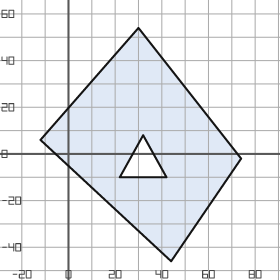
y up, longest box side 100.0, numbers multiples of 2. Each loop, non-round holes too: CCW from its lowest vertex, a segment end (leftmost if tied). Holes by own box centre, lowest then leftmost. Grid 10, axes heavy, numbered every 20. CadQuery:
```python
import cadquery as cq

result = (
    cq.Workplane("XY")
    .moveTo(44.0, -46.0)
    .lineTo(74.0, -2.0)
    .lineTo(30.0, 54.0)
    .lineTo(-12.0, 6.0)
    .close()
    .moveTo(22.0, -10.0)
    .lineTo(42.0, -10.0)
    .lineTo(32.0, 8.0)
    .close()
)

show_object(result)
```